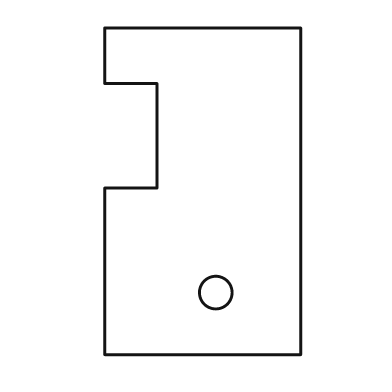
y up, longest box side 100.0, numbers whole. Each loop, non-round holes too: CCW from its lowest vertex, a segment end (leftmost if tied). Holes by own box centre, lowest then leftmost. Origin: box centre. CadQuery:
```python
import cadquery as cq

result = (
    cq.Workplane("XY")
    .moveTo(-30.0, -50.0)
    .lineTo(30.0, -50.0)
    .lineTo(30.0, 50.0)
    .lineTo(-30.0, 50.0)
    .lineTo(-30.0, 33.0)
    .lineTo(-14.0, 33.0)
    .lineTo(-14.0, 1.0)
    .lineTo(-30.0, 1.0)
    .close()
    .moveTo(4.0, -31.0)
    .circle(5.0)
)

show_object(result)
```